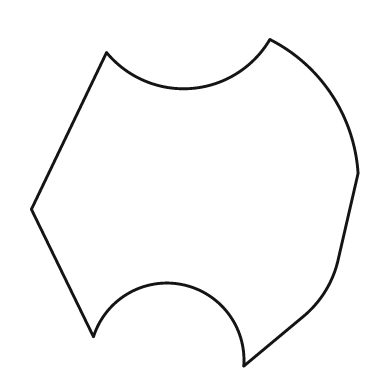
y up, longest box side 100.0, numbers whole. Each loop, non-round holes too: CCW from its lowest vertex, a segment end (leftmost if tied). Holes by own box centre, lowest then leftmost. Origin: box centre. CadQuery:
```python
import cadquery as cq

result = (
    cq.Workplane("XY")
    .moveTo(15.0, -50.0)
    .lineTo(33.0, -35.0)
    .threePointArc((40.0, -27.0), (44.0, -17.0))
    .lineTo(50.0, 9.0)
    .threePointArc((42.0, 33.0), (23.0, 50.0))
    .threePointArc((-1.0, 35.0), (-27.0, 46.0))
    .lineTo(-50.0, -2.0)
    .lineTo(-31.0, -41.0)
    .threePointArc((-4.0, -25.0), (15.0, -50.0))
    .close()
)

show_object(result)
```